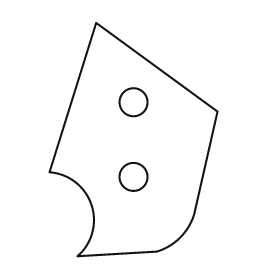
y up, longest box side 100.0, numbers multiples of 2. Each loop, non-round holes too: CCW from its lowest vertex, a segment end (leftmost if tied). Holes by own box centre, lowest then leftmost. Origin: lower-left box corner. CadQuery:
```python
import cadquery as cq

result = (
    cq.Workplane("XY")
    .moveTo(12.0, 0.0)
    .lineTo(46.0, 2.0)
    .threePointArc((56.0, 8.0), (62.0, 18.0))
    .lineTo(72.0, 62.0)
    .lineTo(20.0, 100.0)
    .lineTo(0.0, 36.0)
    .threePointArc((18.0, 22.0), (12.0, 0.0))
    .close()
    .moveTo(36.0, 34.0)
    .circle(6.0)
    .moveTo(36.0, 66.0)
    .circle(6.0)
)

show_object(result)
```